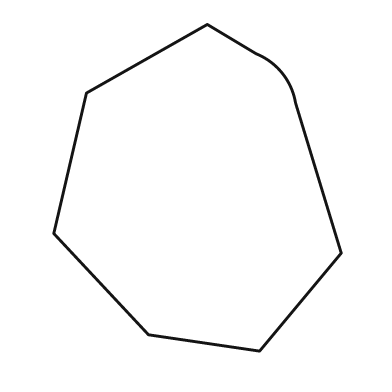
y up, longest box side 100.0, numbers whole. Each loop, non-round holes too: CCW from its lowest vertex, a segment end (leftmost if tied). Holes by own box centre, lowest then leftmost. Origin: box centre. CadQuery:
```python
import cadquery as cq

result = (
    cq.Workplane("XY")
    .moveTo(19.0, -50.0)
    .lineTo(44.0, -20.0)
    .lineTo(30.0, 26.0)
    .threePointArc((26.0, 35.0), (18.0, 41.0))
    .lineTo(3.0, 50.0)
    .lineTo(-34.0, 29.0)
    .lineTo(-44.0, -14.0)
    .lineTo(-15.0, -45.0)
    .close()
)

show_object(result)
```